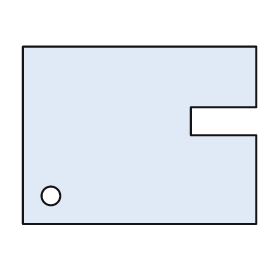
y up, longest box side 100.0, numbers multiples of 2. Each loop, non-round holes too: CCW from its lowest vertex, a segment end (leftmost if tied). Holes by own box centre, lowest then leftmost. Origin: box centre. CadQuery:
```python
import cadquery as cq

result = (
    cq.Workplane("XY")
    .moveTo(-50.0, -38.0)
    .lineTo(50.0, -38.0)
    .lineTo(50.0, 0.0)
    .lineTo(22.0, 0.0)
    .lineTo(22.0, 12.0)
    .lineTo(50.0, 12.0)
    .lineTo(50.0, 38.0)
    .lineTo(-50.0, 38.0)
    .close()
    .moveTo(-38.0, -26.0)
    .circle(4.0)
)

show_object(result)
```